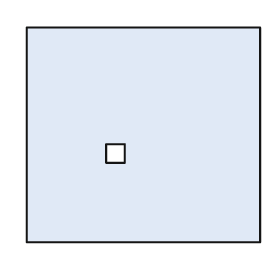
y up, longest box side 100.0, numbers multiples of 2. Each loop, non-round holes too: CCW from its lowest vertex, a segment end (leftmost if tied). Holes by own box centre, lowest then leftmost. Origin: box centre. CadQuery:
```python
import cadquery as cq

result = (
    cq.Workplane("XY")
    .moveTo(-50.0, -46.0)
    .lineTo(50.0, -46.0)
    .lineTo(50.0, 46.0)
    .lineTo(-50.0, 46.0)
    .close()
    .moveTo(-16.0, -12.0)
    .lineTo(-8.0, -12.0)
    .lineTo(-8.0, -4.0)
    .lineTo(-16.0, -4.0)
    .close()
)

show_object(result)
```